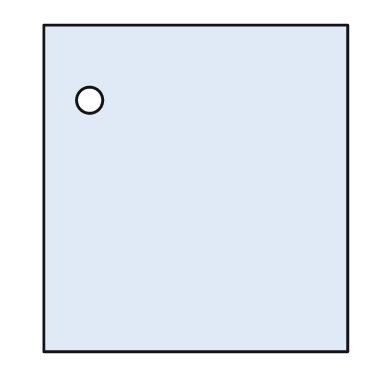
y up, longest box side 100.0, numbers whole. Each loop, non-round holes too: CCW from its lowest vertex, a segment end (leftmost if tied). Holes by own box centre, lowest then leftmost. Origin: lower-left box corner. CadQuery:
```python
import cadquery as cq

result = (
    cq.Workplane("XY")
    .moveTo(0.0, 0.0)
    .lineTo(93.0, 0.0)
    .lineTo(93.0, 100.0)
    .lineTo(0.0, 100.0)
    .close()
    .moveTo(14.0, 77.0)
    .circle(4.0)
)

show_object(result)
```